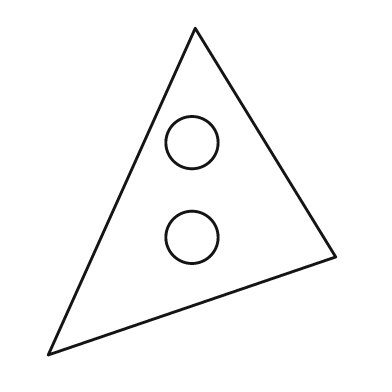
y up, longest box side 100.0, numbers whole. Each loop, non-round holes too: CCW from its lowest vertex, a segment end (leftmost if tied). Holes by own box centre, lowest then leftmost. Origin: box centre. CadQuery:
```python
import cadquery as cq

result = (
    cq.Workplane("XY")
    .moveTo(-44.0, -50.0)
    .lineTo(44.0, -20.0)
    .lineTo(1.0, 50.0)
    .close()
    .moveTo(0.0, -14.0)
    .circle(8.0)
    .moveTo(0.0, 15.0)
    .circle(8.0)
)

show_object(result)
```